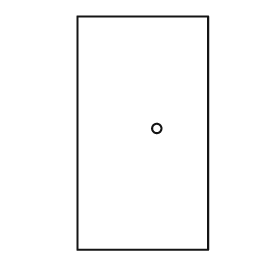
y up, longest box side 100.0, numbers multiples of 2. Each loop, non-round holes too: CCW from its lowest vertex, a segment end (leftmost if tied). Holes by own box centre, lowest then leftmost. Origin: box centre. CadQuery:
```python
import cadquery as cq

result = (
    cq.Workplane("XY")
    .moveTo(-28.0, -50.0)
    .lineTo(28.0, -50.0)
    .lineTo(28.0, 50.0)
    .lineTo(-28.0, 50.0)
    .close()
    .moveTo(6.0, 2.0)
    .circle(2.0)
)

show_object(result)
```